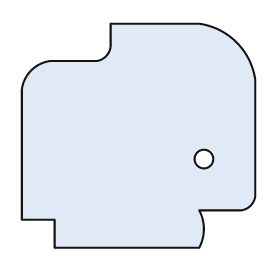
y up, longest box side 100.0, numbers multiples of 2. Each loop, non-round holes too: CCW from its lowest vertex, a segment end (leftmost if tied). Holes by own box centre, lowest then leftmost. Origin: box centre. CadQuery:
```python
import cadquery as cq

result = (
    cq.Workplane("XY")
    .moveTo(-36.0, -48.0)
    .lineTo(26.0, -48.0)
    .threePointArc((28.0, -40.0), (26.0, -32.0))
    .lineTo(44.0, -32.0)
    .threePointArc((48.0, -30.0), (50.0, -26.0))
    .lineTo(50.0, 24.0)
    .threePointArc((42.0, 40.0), (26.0, 48.0))
    .lineTo(-12.0, 48.0)
    .lineTo(-12.0, 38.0)
    .threePointArc((-14.0, 34.0), (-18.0, 32.0))
    .lineTo(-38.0, 32.0)
    .threePointArc((-46.0, 28.0), (-50.0, 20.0))
    .lineTo(-50.0, -36.0)
    .lineTo(-36.0, -36.0)
    .close()
    .moveTo(28.0, -10.0)
    .circle(4.0)
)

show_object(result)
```